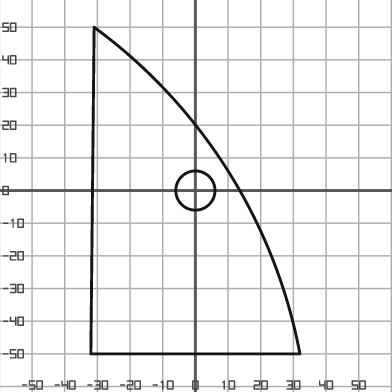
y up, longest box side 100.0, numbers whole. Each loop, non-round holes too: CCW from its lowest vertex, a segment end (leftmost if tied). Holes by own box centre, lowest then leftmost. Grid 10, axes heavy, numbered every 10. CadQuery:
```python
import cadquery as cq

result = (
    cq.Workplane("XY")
    .moveTo(-32.0, -50.0)
    .lineTo(32.0, -50.0)
    .threePointArc((10.0, 6.0), (-31.0, 50.0))
    .close()
    .moveTo(0.0, 0.0)
    .circle(6.0)
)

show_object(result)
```